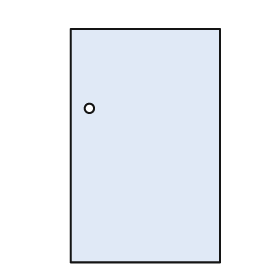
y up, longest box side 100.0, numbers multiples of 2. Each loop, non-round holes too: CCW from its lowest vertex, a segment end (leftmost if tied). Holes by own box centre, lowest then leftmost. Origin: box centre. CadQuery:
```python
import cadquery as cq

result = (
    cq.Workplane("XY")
    .moveTo(-32.0, -50.0)
    .lineTo(32.0, -50.0)
    .lineTo(32.0, 50.0)
    .lineTo(-32.0, 50.0)
    .close()
    .moveTo(-24.0, 16.0)
    .circle(2.0)
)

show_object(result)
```